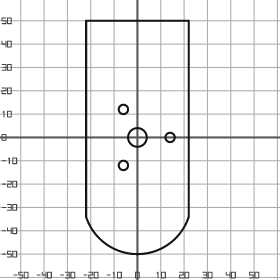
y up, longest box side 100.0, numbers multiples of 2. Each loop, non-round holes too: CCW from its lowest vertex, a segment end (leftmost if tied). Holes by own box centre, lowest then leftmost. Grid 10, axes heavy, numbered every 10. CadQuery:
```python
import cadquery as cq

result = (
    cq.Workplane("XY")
    .moveTo(-22.0, -34.0)
    .threePointArc((0.0, -50.0), (22.0, -34.0))
    .lineTo(22.0, 50.0)
    .lineTo(-22.0, 50.0)
    .close()
    .moveTo(-6.0, -12.0)
    .circle(2.0)
    .moveTo(0.0, 0.0)
    .circle(4.0)
    .moveTo(14.0, 0.0)
    .circle(2.0)
    .moveTo(-6.0, 12.0)
    .circle(2.0)
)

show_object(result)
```